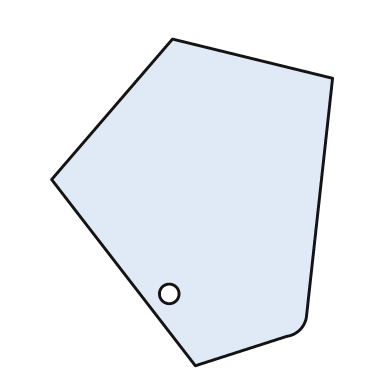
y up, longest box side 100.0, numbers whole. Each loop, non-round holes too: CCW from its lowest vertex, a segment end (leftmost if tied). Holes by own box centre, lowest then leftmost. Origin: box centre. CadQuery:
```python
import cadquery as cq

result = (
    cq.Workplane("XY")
    .moveTo(1.0, -50.0)
    .lineTo(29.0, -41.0)
    .threePointArc((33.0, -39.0), (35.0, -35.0))
    .lineTo(43.0, 38.0)
    .lineTo(-6.0, 50.0)
    .lineTo(-43.0, 7.0)
    .close()
    .moveTo(-7.0, -28.0)
    .circle(3.0)
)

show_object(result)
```